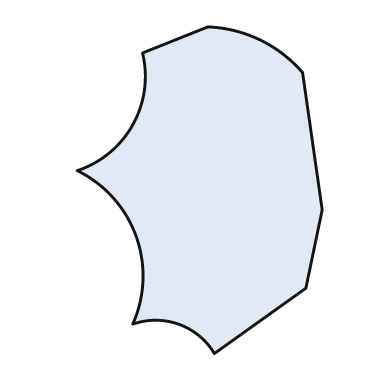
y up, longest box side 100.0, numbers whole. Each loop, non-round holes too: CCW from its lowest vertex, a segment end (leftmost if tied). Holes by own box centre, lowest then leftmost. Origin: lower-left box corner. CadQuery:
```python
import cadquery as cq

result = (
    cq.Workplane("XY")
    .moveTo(42.0, 0.0)
    .lineTo(70.0, 20.0)
    .lineTo(75.0, 44.0)
    .lineTo(69.0, 86.0)
    .threePointArc((56.0, 96.0), (40.0, 100.0))
    .lineTo(20.0, 92.0)
    .threePointArc((17.0, 70.0), (0.0, 56.0))
    .threePointArc((18.0, 36.0), (17.0, 9.0))
    .threePointArc((31.0, 9.0), (42.0, 0.0))
    .close()
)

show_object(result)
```